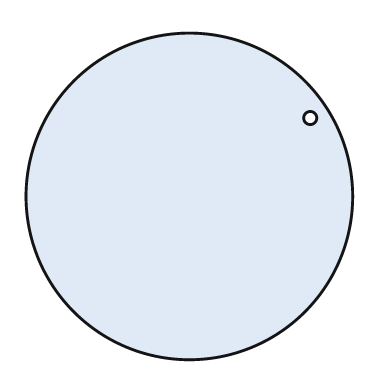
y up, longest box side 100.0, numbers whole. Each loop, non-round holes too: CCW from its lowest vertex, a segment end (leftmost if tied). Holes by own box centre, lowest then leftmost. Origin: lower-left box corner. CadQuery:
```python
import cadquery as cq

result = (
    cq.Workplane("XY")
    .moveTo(50.0, 50.0)
    .circle(50.0)
    .moveTo(87.0, 74.0)
    .circle(2.0)
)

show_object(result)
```